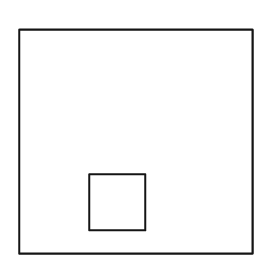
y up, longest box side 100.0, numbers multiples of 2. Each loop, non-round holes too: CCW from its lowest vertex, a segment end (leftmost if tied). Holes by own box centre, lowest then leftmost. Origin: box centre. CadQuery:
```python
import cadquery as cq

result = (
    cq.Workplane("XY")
    .moveTo(-50.0, -48.0)
    .lineTo(50.0, -48.0)
    .lineTo(50.0, 48.0)
    .lineTo(-50.0, 48.0)
    .close()
    .moveTo(-20.0, -38.0)
    .lineTo(4.0, -38.0)
    .lineTo(4.0, -14.0)
    .lineTo(-20.0, -14.0)
    .close()
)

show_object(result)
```